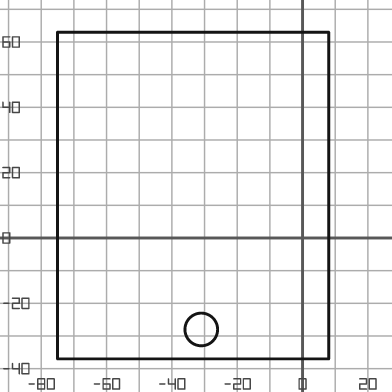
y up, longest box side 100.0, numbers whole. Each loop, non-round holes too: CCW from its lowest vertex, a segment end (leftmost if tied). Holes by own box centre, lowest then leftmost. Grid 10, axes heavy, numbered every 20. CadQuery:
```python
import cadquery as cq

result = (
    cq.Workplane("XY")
    .moveTo(-75.0, -37.0)
    .lineTo(8.0, -37.0)
    .lineTo(8.0, 63.0)
    .lineTo(-75.0, 63.0)
    .close()
    .moveTo(-31.0, -28.0)
    .circle(5.0)
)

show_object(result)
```